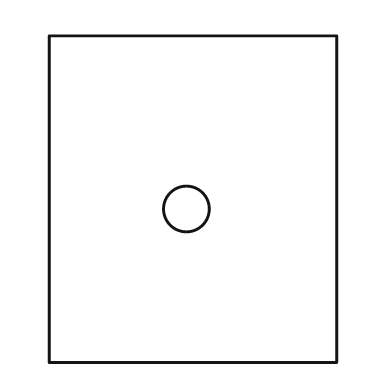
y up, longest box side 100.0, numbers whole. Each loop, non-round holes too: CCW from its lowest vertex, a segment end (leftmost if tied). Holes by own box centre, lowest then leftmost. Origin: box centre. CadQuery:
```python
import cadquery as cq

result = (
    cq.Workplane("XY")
    .moveTo(-44.0, -50.0)
    .lineTo(44.0, -50.0)
    .lineTo(44.0, 50.0)
    .lineTo(-44.0, 50.0)
    .close()
    .moveTo(-2.0, -3.0)
    .circle(7.0)
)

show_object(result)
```